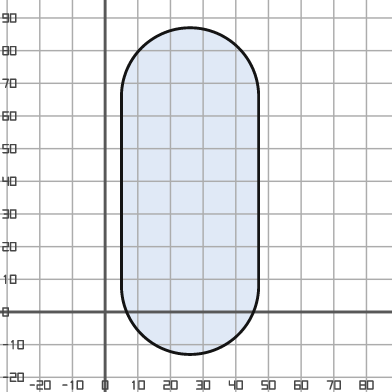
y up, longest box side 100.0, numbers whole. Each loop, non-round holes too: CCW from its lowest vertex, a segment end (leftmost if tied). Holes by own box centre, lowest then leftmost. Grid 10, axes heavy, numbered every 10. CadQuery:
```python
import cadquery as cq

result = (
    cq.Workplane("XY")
    .moveTo(5.0, 8.0)
    .threePointArc((26.0, -13.0), (47.0, 8.0))
    .lineTo(47.0, 66.0)
    .threePointArc((26.0, 87.0), (5.0, 66.0))
    .close()
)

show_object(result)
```